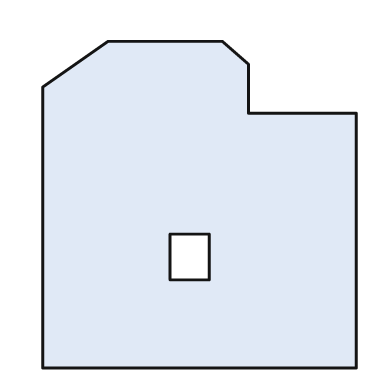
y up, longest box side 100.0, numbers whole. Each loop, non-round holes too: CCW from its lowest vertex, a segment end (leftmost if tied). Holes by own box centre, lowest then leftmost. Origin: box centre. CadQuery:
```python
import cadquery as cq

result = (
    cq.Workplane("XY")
    .moveTo(-48.0, -50.0)
    .lineTo(48.0, -50.0)
    .lineTo(48.0, 28.0)
    .lineTo(15.0, 28.0)
    .lineTo(15.0, 43.0)
    .lineTo(7.0, 50.0)
    .lineTo(-28.0, 50.0)
    .lineTo(-48.0, 36.0)
    .close()
    .moveTo(-9.0, -23.0)
    .lineTo(3.0, -23.0)
    .lineTo(3.0, -9.0)
    .lineTo(-9.0, -9.0)
    .close()
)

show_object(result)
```